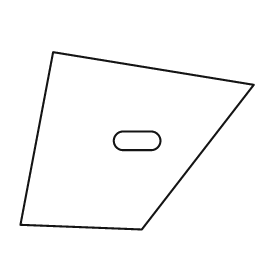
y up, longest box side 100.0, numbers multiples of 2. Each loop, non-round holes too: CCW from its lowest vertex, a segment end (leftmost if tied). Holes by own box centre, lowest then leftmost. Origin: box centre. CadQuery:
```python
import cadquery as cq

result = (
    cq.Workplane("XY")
    .moveTo(2.0, -38.0)
    .lineTo(50.0, 24.0)
    .lineTo(-36.0, 38.0)
    .lineTo(-50.0, -36.0)
    .close()
    .moveTo(-6.0, -4.0)
    .lineTo(6.0, -4.0)
    .threePointArc((10.0, 0.0), (6.0, 4.0))
    .lineTo(-6.0, 4.0)
    .threePointArc((-10.0, 0.0), (-6.0, -4.0))
    .close()
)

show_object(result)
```